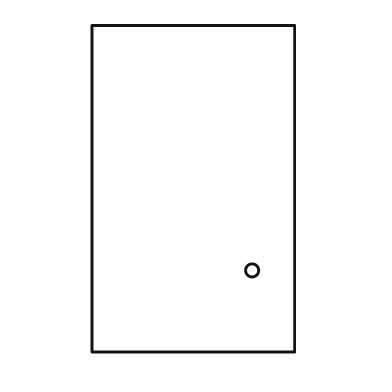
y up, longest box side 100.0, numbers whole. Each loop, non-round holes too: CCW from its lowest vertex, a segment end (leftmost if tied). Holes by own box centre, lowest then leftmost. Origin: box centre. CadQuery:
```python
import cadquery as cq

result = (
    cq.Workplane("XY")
    .moveTo(-31.0, -50.0)
    .lineTo(31.0, -50.0)
    .lineTo(31.0, 50.0)
    .lineTo(-31.0, 50.0)
    .close()
    .moveTo(18.0, -25.0)
    .circle(2.0)
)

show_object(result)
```